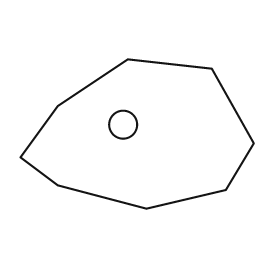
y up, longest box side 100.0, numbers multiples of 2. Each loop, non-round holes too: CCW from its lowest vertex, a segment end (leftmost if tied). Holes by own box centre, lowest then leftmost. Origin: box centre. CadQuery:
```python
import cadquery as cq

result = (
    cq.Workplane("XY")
    .moveTo(4.0, -32.0)
    .lineTo(38.0, -24.0)
    .lineTo(50.0, -4.0)
    .lineTo(32.0, 28.0)
    .lineTo(-4.0, 32.0)
    .lineTo(-34.0, 12.0)
    .lineTo(-50.0, -10.0)
    .lineTo(-34.0, -22.0)
    .close()
    .moveTo(-6.0, 4.0)
    .circle(6.0)
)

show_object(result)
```